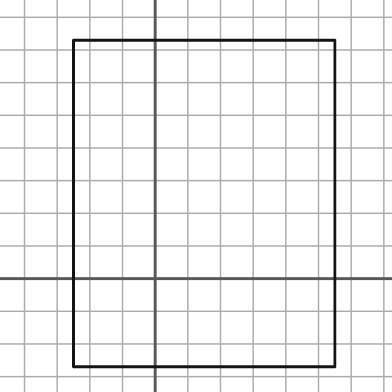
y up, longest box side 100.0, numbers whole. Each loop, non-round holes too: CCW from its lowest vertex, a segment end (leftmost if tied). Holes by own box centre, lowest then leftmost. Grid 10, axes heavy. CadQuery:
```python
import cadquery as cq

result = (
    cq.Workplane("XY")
    .moveTo(-25.0, -27.0)
    .lineTo(55.0, -27.0)
    .lineTo(55.0, 73.0)
    .lineTo(-25.0, 73.0)
    .close()
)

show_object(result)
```